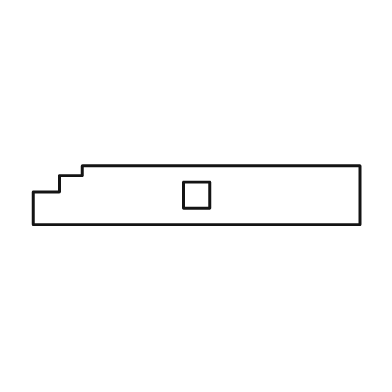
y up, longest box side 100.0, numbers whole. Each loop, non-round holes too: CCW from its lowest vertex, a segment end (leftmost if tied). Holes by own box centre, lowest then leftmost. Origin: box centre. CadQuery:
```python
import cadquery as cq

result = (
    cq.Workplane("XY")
    .moveTo(-50.0, -9.0)
    .lineTo(50.0, -9.0)
    .lineTo(50.0, 9.0)
    .lineTo(-35.0, 9.0)
    .lineTo(-35.0, 6.0)
    .lineTo(-42.0, 6.0)
    .lineTo(-42.0, 1.0)
    .lineTo(-50.0, 1.0)
    .close()
    .moveTo(-4.0, -4.0)
    .lineTo(4.0, -4.0)
    .lineTo(4.0, 4.0)
    .lineTo(-4.0, 4.0)
    .close()
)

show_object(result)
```